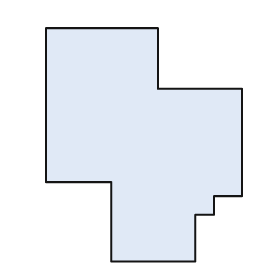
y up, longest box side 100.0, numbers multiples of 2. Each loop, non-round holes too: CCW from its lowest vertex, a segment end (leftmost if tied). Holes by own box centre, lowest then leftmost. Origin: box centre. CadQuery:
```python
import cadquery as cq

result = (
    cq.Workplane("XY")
    .moveTo(-14.0, -50.0)
    .lineTo(22.0, -50.0)
    .lineTo(22.0, -30.0)
    .lineTo(30.0, -30.0)
    .lineTo(30.0, -22.0)
    .lineTo(42.0, -22.0)
    .lineTo(42.0, 24.0)
    .lineTo(6.0, 24.0)
    .lineTo(6.0, 50.0)
    .lineTo(-42.0, 50.0)
    .lineTo(-42.0, -16.0)
    .lineTo(-14.0, -16.0)
    .close()
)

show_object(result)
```